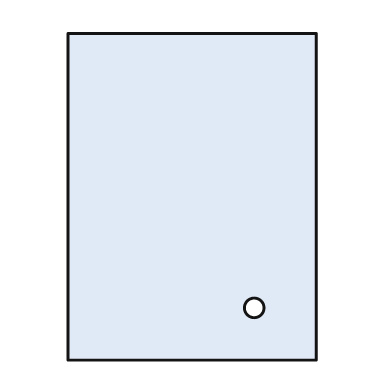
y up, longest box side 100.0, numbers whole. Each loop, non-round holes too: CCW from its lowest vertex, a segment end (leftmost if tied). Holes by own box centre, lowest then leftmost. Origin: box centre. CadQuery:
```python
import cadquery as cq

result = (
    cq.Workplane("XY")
    .moveTo(-38.0, -50.0)
    .lineTo(38.0, -50.0)
    .lineTo(38.0, 50.0)
    .lineTo(-38.0, 50.0)
    .close()
    .moveTo(19.0, -34.0)
    .circle(3.0)
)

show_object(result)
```